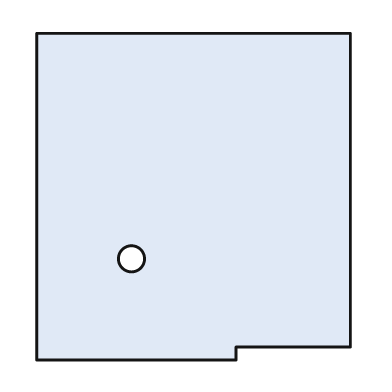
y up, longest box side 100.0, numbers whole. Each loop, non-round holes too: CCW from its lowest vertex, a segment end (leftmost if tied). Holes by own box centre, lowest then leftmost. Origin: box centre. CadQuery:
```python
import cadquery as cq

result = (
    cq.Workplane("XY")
    .moveTo(-48.0, -50.0)
    .lineTo(13.0, -50.0)
    .lineTo(13.0, -46.0)
    .lineTo(48.0, -46.0)
    .lineTo(48.0, 50.0)
    .lineTo(-48.0, 50.0)
    .close()
    .moveTo(-19.0, -19.0)
    .circle(4.0)
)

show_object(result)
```